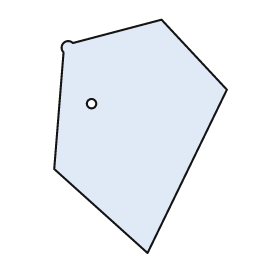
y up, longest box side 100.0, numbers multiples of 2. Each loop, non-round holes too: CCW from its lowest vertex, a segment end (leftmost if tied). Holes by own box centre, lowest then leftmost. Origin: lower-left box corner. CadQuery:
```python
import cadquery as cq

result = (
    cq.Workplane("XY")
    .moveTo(40.0, 0.0)
    .lineTo(74.0, 70.0)
    .lineTo(46.0, 100.0)
    .lineTo(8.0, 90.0)
    .threePointArc((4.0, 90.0), (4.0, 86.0))
    .lineTo(0.0, 36.0)
    .close()
    .moveTo(16.0, 64.0)
    .circle(2.0)
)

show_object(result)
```